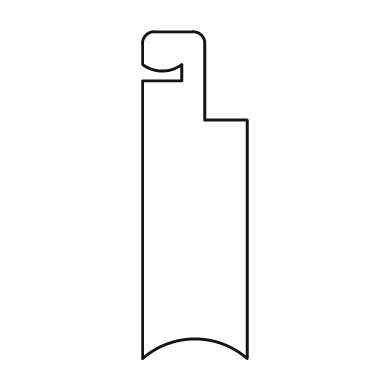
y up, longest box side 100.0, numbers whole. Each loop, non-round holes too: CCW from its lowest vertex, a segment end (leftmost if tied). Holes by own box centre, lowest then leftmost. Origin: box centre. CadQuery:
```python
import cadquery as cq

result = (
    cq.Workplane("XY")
    .moveTo(-16.0, -50.0)
    .threePointArc((0.0, -44.0), (16.0, -50.0))
    .lineTo(16.0, 23.0)
    .lineTo(3.0, 23.0)
    .lineTo(3.0, 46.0)
    .threePointArc((2.0, 49.0), (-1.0, 50.0))
    .lineTo(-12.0, 50.0)
    .threePointArc((-15.0, 49.0), (-16.0, 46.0))
    .lineTo(-16.0, 40.0)
    .threePointArc((-10.0, 38.0), (-4.0, 40.0))
    .lineTo(-4.0, 35.0)
    .lineTo(-16.0, 35.0)
    .close()
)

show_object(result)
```